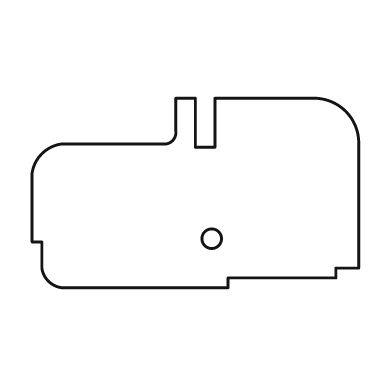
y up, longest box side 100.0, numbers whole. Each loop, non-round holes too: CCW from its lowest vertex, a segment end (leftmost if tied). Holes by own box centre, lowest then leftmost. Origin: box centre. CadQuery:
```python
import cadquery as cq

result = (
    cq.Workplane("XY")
    .moveTo(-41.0, -29.0)
    .lineTo(10.0, -29.0)
    .lineTo(10.0, -26.0)
    .lineTo(43.0, -26.0)
    .lineTo(43.0, -23.0)
    .lineTo(50.0, -23.0)
    .lineTo(50.0, 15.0)
    .threePointArc((46.0, 25.0), (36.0, 29.0))
    .lineTo(6.0, 29.0)
    .lineTo(6.0, 14.0)
    .lineTo(0.0, 14.0)
    .lineTo(0.0, 29.0)
    .lineTo(-6.0, 29.0)
    .lineTo(-6.0, 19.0)
    .threePointArc((-7.0, 16.0), (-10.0, 15.0))
    .lineTo(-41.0, 15.0)
    .threePointArc((-47.0, 12.0), (-50.0, 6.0))
    .lineTo(-50.0, -15.0)
    .lineTo(-47.0, -15.0)
    .lineTo(-47.0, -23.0)
    .threePointArc((-45.0, -27.0), (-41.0, -29.0))
    .close()
    .moveTo(5.0, -14.0)
    .circle(3.0)
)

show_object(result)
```